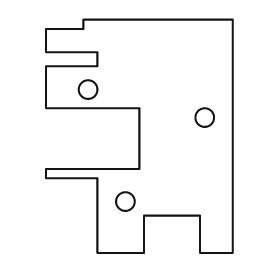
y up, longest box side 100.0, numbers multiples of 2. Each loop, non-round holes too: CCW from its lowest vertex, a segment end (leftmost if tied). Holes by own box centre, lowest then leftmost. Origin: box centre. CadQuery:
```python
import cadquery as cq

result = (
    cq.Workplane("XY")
    .moveTo(-18.0, -50.0)
    .lineTo(2.0, -50.0)
    .lineTo(2.0, -34.0)
    .lineTo(26.0, -34.0)
    .lineTo(26.0, -50.0)
    .lineTo(40.0, -50.0)
    .lineTo(40.0, 50.0)
    .lineTo(-24.0, 50.0)
    .lineTo(-24.0, 46.0)
    .lineTo(-40.0, 46.0)
    .lineTo(-40.0, 36.0)
    .lineTo(-18.0, 36.0)
    .lineTo(-18.0, 30.0)
    .lineTo(-40.0, 30.0)
    .lineTo(-40.0, 12.0)
    .lineTo(0.0, 12.0)
    .lineTo(0.0, -14.0)
    .lineTo(-40.0, -14.0)
    .lineTo(-40.0, -18.0)
    .lineTo(-18.0, -18.0)
    .close()
    .moveTo(-6.0, -28.0)
    .circle(4.0)
    .moveTo(28.0, 8.0)
    .circle(4.0)
    .moveTo(-22.0, 20.0)
    .circle(4.0)
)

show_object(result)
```